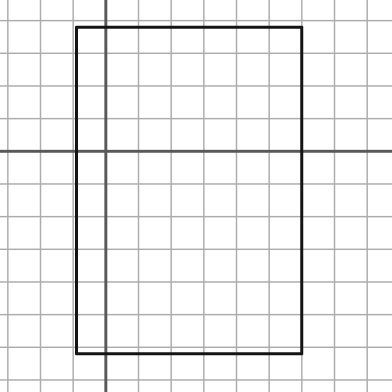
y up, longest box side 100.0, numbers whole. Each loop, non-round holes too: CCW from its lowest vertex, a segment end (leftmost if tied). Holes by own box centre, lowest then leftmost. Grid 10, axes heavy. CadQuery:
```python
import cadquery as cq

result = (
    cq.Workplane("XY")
    .moveTo(-9.0, -62.0)
    .lineTo(60.0, -62.0)
    .lineTo(60.0, 38.0)
    .lineTo(-9.0, 38.0)
    .close()
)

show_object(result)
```